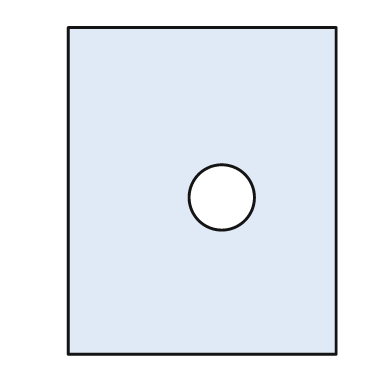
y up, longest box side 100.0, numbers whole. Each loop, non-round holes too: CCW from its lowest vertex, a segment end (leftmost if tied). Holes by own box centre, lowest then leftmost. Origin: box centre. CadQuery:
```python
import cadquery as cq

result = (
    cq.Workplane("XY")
    .moveTo(-41.0, -50.0)
    .lineTo(41.0, -50.0)
    .lineTo(41.0, 50.0)
    .lineTo(-41.0, 50.0)
    .close()
    .moveTo(6.0, -2.0)
    .circle(10.0)
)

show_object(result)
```